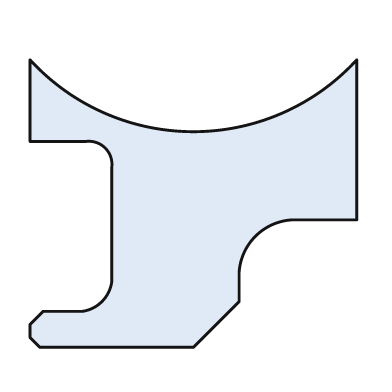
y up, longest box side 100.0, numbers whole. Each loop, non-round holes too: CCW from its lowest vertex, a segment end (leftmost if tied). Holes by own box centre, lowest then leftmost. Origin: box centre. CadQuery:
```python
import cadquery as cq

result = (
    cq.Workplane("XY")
    .moveTo(-47.0, -44.0)
    .lineTo(0.0, -44.0)
    .lineTo(14.0, -30.0)
    .lineTo(14.0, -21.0)
    .threePointArc((19.0, -10.0), (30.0, -5.0))
    .lineTo(50.0, -5.0)
    .lineTo(50.0, 44.0)
    .threePointArc((0.0, 22.0), (-50.0, 44.0))
    .lineTo(-50.0, 19.0)
    .lineTo(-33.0, 19.0)
    .threePointArc((-27.0, 17.0), (-25.0, 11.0))
    .lineTo(-25.0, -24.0)
    .threePointArc((-28.0, -30.0), (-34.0, -33.0))
    .lineTo(-46.0, -33.0)
    .lineTo(-50.0, -37.0)
    .lineTo(-50.0, -41.0)
    .close()
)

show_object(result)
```